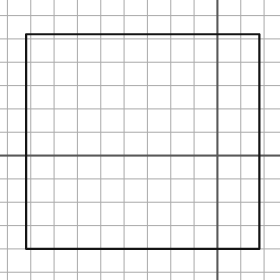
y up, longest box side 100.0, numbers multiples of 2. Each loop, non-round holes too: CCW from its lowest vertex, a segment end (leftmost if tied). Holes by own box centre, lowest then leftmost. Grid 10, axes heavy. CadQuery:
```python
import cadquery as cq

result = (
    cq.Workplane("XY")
    .moveTo(-82.0, -40.0)
    .lineTo(18.0, -40.0)
    .lineTo(18.0, 52.0)
    .lineTo(-82.0, 52.0)
    .close()
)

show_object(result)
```